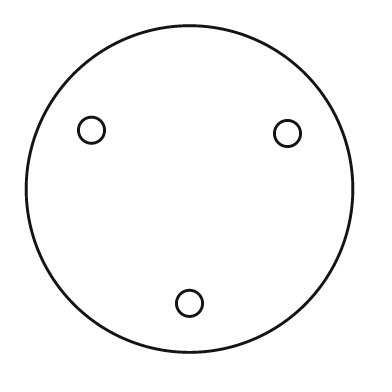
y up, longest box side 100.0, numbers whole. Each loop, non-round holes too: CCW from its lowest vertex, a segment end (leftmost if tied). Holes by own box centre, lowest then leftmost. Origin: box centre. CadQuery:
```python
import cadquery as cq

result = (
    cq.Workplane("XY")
    .moveTo(0.0, 0.0)
    .circle(50.0)
    .moveTo(0.0, -35.0)
    .circle(4.0)
    .moveTo(30.0, 17.0)
    .circle(4.0)
    .moveTo(-30.0, 18.0)
    .circle(4.0)
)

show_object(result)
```